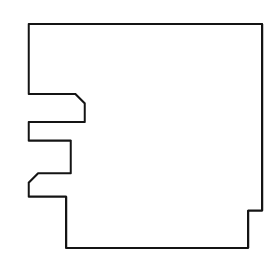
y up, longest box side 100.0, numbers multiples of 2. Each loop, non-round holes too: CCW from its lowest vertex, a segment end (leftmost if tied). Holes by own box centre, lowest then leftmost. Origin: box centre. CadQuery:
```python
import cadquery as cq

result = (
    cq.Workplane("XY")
    .moveTo(-34.0, -48.0)
    .lineTo(44.0, -48.0)
    .lineTo(44.0, -32.0)
    .lineTo(50.0, -32.0)
    .lineTo(50.0, 48.0)
    .lineTo(-50.0, 48.0)
    .lineTo(-50.0, 18.0)
    .lineTo(-30.0, 18.0)
    .lineTo(-26.0, 14.0)
    .lineTo(-26.0, 6.0)
    .lineTo(-50.0, 6.0)
    .lineTo(-50.0, -2.0)
    .lineTo(-32.0, -2.0)
    .lineTo(-32.0, -16.0)
    .lineTo(-46.0, -16.0)
    .lineTo(-50.0, -20.0)
    .lineTo(-50.0, -26.0)
    .lineTo(-34.0, -26.0)
    .close()
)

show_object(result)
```